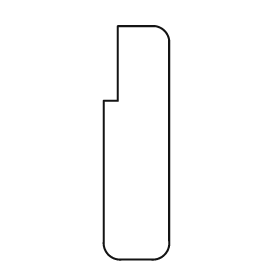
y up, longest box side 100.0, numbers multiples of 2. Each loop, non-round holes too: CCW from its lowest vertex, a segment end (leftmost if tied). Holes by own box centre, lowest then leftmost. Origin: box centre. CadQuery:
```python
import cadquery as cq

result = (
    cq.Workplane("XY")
    .moveTo(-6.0, -50.0)
    .lineTo(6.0, -50.0)
    .threePointArc((12.0, -48.0), (14.0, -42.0))
    .lineTo(14.0, 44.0)
    .threePointArc((12.0, 48.0), (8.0, 50.0))
    .lineTo(-8.0, 50.0)
    .lineTo(-8.0, 18.0)
    .lineTo(-14.0, 18.0)
    .lineTo(-14.0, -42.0)
    .threePointArc((-12.0, -48.0), (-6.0, -50.0))
    .close()
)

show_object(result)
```